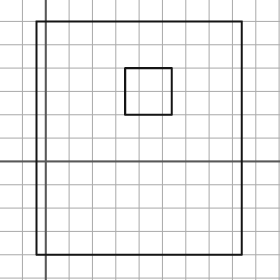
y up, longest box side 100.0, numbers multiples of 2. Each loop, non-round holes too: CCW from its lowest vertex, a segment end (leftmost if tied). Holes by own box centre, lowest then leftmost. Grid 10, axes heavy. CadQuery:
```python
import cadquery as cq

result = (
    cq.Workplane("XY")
    .moveTo(-4.0, -40.0)
    .lineTo(84.0, -40.0)
    .lineTo(84.0, 60.0)
    .lineTo(-4.0, 60.0)
    .close()
    .moveTo(34.0, 20.0)
    .lineTo(54.0, 20.0)
    .lineTo(54.0, 40.0)
    .lineTo(34.0, 40.0)
    .close()
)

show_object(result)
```